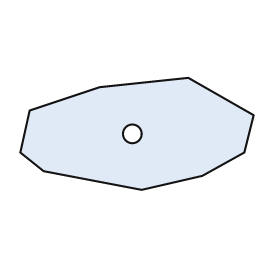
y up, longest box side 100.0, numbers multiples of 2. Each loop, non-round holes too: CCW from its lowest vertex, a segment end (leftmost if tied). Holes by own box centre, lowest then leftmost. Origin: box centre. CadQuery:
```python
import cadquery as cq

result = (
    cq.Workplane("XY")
    .moveTo(2.0, -24.0)
    .lineTo(28.0, -18.0)
    .lineTo(46.0, -8.0)
    .lineTo(50.0, 8.0)
    .lineTo(22.0, 24.0)
    .lineTo(-16.0, 20.0)
    .lineTo(-46.0, 10.0)
    .lineTo(-50.0, -8.0)
    .lineTo(-40.0, -16.0)
    .close()
    .moveTo(-2.0, 0.0)
    .circle(4.0)
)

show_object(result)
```